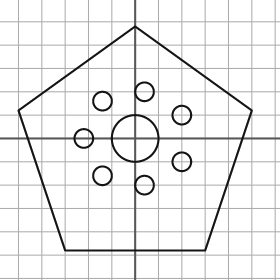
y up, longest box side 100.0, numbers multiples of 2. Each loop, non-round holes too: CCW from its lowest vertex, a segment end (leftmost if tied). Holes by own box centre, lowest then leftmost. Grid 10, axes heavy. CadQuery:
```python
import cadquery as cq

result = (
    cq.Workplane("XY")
    .moveTo(-30.0, -48.0)
    .lineTo(30.0, -48.0)
    .lineTo(50.0, 12.0)
    .lineTo(0.0, 48.0)
    .lineTo(-50.0, 12.0)
    .close()
    .moveTo(4.0, -20.0)
    .circle(4.0)
    .moveTo(-14.0, -16.0)
    .circle(4.0)
    .moveTo(20.0, -10.0)
    .circle(4.0)
    .moveTo(-22.0, 0.0)
    .circle(4.0)
    .moveTo(0.0, 0.0)
    .circle(10.0)
    .moveTo(20.0, 10.0)
    .circle(4.0)
    .moveTo(-14.0, 16.0)
    .circle(4.0)
    .moveTo(4.0, 20.0)
    .circle(4.0)
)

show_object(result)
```